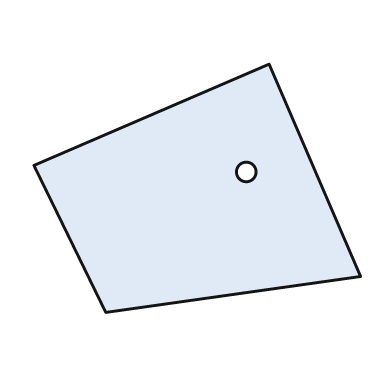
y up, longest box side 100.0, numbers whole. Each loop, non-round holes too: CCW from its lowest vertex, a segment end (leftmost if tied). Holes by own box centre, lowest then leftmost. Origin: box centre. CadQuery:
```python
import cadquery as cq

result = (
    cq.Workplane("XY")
    .moveTo(-28.0, -38.0)
    .lineTo(50.0, -27.0)
    .lineTo(22.0, 38.0)
    .lineTo(-50.0, 7.0)
    .close()
    .moveTo(15.0, 5.0)
    .circle(3.0)
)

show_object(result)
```